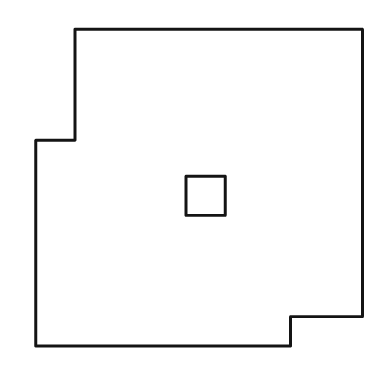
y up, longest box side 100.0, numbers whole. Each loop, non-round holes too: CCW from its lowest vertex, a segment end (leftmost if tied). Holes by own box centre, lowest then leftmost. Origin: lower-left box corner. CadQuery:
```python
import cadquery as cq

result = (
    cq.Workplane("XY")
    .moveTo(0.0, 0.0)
    .lineTo(78.0, 0.0)
    .lineTo(78.0, 9.0)
    .lineTo(100.0, 9.0)
    .lineTo(100.0, 97.0)
    .lineTo(12.0, 97.0)
    .lineTo(12.0, 63.0)
    .lineTo(0.0, 63.0)
    .close()
    .moveTo(46.0, 40.0)
    .lineTo(58.0, 40.0)
    .lineTo(58.0, 52.0)
    .lineTo(46.0, 52.0)
    .close()
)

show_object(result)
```